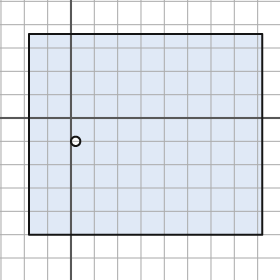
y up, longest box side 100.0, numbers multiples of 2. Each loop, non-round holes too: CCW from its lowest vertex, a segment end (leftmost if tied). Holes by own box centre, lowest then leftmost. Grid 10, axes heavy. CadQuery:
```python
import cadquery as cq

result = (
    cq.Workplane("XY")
    .moveTo(-18.0, -50.0)
    .lineTo(82.0, -50.0)
    .lineTo(82.0, 36.0)
    .lineTo(-18.0, 36.0)
    .close()
    .moveTo(2.0, -10.0)
    .circle(2.0)
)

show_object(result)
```